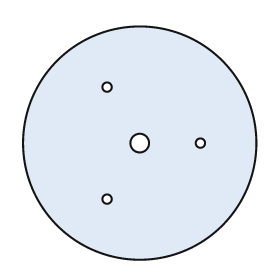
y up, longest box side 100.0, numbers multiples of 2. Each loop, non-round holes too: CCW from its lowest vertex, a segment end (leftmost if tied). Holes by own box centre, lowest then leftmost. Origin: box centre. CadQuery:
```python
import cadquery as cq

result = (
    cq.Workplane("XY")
    .moveTo(0.0, 0.0)
    .circle(50.0)
    .moveTo(-14.0, -24.0)
    .circle(2.0)
    .moveTo(0.0, 0.0)
    .circle(4.0)
    .moveTo(26.0, 0.0)
    .circle(2.0)
    .moveTo(-14.0, 24.0)
    .circle(2.0)
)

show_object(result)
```